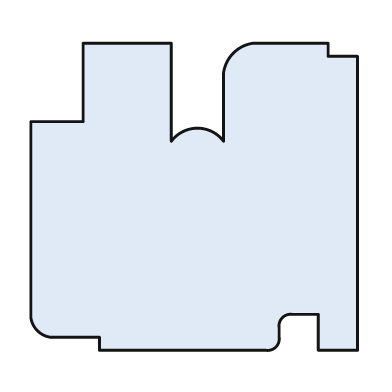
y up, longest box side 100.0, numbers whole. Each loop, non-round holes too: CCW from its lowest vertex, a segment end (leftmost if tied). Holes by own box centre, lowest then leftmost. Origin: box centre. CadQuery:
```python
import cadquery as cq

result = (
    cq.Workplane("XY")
    .moveTo(-29.0, -47.0)
    .lineTo(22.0, -47.0)
    .threePointArc((25.0, -46.0), (26.0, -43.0))
    .lineTo(26.0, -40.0)
    .threePointArc((27.0, -37.0), (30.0, -36.0))
    .lineTo(38.0, -36.0)
    .lineTo(38.0, -47.0)
    .lineTo(50.0, -47.0)
    .lineTo(50.0, 43.0)
    .lineTo(41.0, 43.0)
    .lineTo(41.0, 47.0)
    .lineTo(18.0, 47.0)
    .threePointArc((12.0, 44.0), (9.0, 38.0))
    .lineTo(9.0, 17.0)
    .threePointArc((1.0, 21.0), (-7.0, 17.0))
    .lineTo(-7.0, 47.0)
    .lineTo(-34.0, 47.0)
    .lineTo(-34.0, 23.0)
    .lineTo(-50.0, 23.0)
    .lineTo(-50.0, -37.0)
    .threePointArc((-48.0, -41.0), (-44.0, -43.0))
    .lineTo(-29.0, -43.0)
    .close()
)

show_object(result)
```